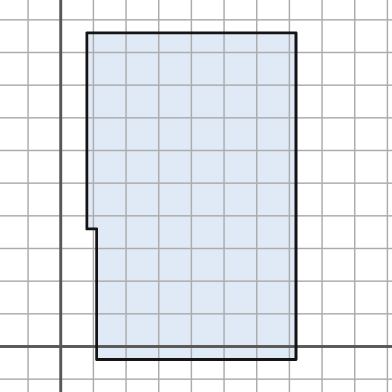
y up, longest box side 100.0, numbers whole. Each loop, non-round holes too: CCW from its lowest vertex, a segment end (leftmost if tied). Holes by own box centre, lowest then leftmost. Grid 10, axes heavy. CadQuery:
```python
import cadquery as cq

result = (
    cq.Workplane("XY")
    .moveTo(11.0, -4.0)
    .lineTo(72.0, -4.0)
    .lineTo(72.0, 96.0)
    .lineTo(8.0, 96.0)
    .lineTo(8.0, 36.0)
    .lineTo(11.0, 36.0)
    .close()
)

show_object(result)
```